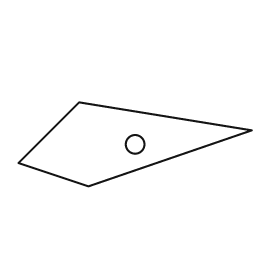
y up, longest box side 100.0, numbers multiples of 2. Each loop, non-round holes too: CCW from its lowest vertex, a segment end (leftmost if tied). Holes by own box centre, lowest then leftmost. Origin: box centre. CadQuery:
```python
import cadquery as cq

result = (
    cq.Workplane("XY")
    .moveTo(-20.0, -18.0)
    .lineTo(50.0, 6.0)
    .lineTo(-24.0, 18.0)
    .lineTo(-50.0, -8.0)
    .close()
    .moveTo(0.0, 0.0)
    .circle(4.0)
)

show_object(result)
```